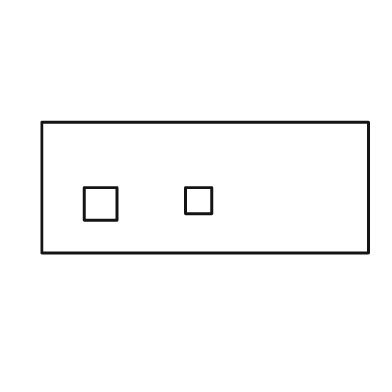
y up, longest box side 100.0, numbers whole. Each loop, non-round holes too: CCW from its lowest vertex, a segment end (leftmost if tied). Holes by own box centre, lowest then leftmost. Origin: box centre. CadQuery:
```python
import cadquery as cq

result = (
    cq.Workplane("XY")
    .moveTo(-50.0, -20.0)
    .lineTo(50.0, -20.0)
    .lineTo(50.0, 20.0)
    .lineTo(-50.0, 20.0)
    .close()
    .moveTo(-37.0, -10.0)
    .lineTo(-27.0, -10.0)
    .lineTo(-27.0, 0.0)
    .lineTo(-37.0, 0.0)
    .close()
    .moveTo(-6.0, -8.0)
    .lineTo(2.0, -8.0)
    .lineTo(2.0, 0.0)
    .lineTo(-6.0, 0.0)
    .close()
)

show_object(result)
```